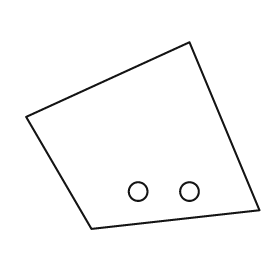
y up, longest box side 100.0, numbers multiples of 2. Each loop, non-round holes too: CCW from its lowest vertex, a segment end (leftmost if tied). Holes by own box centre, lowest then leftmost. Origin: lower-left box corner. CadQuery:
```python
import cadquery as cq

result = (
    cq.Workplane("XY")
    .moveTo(28.0, 0.0)
    .lineTo(100.0, 8.0)
    .lineTo(70.0, 80.0)
    .lineTo(0.0, 48.0)
    .close()
    .moveTo(48.0, 16.0)
    .circle(4.0)
    .moveTo(70.0, 16.0)
    .circle(4.0)
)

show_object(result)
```